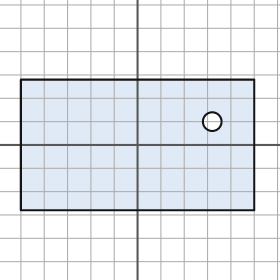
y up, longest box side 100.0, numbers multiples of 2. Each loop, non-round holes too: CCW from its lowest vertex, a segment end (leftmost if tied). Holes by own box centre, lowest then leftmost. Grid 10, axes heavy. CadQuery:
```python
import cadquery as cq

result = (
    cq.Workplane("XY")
    .moveTo(-50.0, -28.0)
    .lineTo(50.0, -28.0)
    .lineTo(50.0, 28.0)
    .lineTo(-50.0, 28.0)
    .close()
    .moveTo(32.0, 10.0)
    .circle(4.0)
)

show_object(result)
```